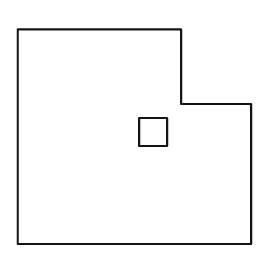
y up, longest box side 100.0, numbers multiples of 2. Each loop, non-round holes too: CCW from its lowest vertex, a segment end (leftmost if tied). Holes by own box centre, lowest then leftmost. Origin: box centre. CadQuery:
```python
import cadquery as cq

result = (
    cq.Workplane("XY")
    .moveTo(-50.0, -46.0)
    .lineTo(50.0, -46.0)
    .lineTo(50.0, 14.0)
    .lineTo(20.0, 14.0)
    .lineTo(20.0, 46.0)
    .lineTo(-50.0, 46.0)
    .close()
    .moveTo(2.0, -4.0)
    .lineTo(14.0, -4.0)
    .lineTo(14.0, 8.0)
    .lineTo(2.0, 8.0)
    .close()
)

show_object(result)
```